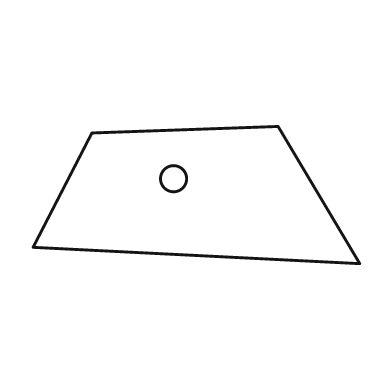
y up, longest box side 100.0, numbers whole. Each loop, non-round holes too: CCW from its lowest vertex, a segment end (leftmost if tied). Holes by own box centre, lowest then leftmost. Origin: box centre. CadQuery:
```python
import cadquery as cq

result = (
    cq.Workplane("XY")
    .moveTo(50.0, -21.0)
    .lineTo(25.0, 21.0)
    .lineTo(-32.0, 19.0)
    .lineTo(-50.0, -16.0)
    .close()
    .moveTo(-7.0, 5.0)
    .circle(4.0)
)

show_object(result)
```